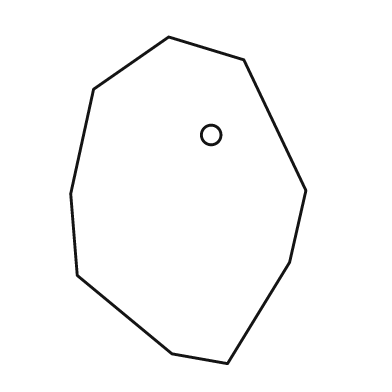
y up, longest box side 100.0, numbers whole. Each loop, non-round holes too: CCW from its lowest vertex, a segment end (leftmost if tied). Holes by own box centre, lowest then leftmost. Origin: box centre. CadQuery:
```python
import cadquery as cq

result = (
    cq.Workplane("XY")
    .moveTo(12.0, -50.0)
    .lineTo(31.0, -19.0)
    .lineTo(36.0, 3.0)
    .lineTo(17.0, 43.0)
    .lineTo(-6.0, 50.0)
    .lineTo(-29.0, 34.0)
    .lineTo(-36.0, 2.0)
    .lineTo(-34.0, -23.0)
    .lineTo(-5.0, -47.0)
    .close()
    .moveTo(7.0, 20.0)
    .circle(3.0)
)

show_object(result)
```